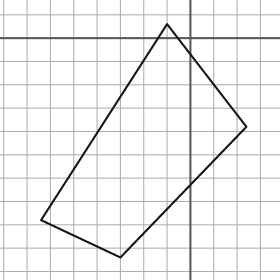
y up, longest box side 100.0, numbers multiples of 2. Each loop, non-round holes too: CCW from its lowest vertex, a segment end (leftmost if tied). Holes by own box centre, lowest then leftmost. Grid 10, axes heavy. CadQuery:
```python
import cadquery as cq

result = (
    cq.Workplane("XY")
    .moveTo(-30.0, -94.0)
    .lineTo(24.0, -38.0)
    .lineTo(-10.0, 6.0)
    .lineTo(-64.0, -78.0)
    .close()
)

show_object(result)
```